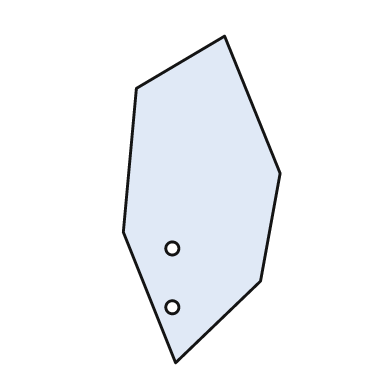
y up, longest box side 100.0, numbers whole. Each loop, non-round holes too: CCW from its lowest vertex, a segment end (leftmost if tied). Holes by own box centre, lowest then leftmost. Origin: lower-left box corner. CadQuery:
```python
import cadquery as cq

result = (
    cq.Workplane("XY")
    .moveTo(16.0, 0.0)
    .lineTo(42.0, 25.0)
    .lineTo(48.0, 58.0)
    .lineTo(31.0, 100.0)
    .lineTo(4.0, 84.0)
    .lineTo(0.0, 40.0)
    .close()
    .moveTo(15.0, 17.0)
    .circle(2.0)
    .moveTo(15.0, 35.0)
    .circle(2.0)
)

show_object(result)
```